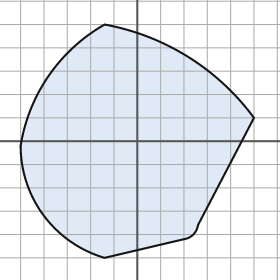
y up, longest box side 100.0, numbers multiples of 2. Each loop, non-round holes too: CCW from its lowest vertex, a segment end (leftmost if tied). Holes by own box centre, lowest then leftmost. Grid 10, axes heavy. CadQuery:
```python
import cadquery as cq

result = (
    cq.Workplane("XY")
    .moveTo(-14.0, -50.0)
    .lineTo(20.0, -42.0)
    .threePointArc((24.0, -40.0), (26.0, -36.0))
    .lineTo(50.0, 10.0)
    .threePointArc((22.0, 36.0), (-14.0, 50.0))
    .threePointArc((-38.0, 28.0), (-50.0, -2.0))
    .threePointArc((-40.0, -32.0), (-14.0, -50.0))
    .close()
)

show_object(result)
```